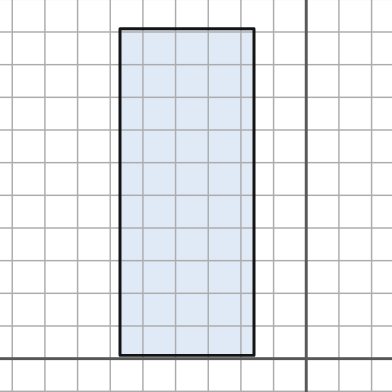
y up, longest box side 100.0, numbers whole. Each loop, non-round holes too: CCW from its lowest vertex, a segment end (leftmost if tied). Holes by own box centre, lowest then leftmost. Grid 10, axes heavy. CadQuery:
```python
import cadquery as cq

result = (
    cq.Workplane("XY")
    .moveTo(-57.0, 1.0)
    .lineTo(-16.0, 1.0)
    .lineTo(-16.0, 101.0)
    .lineTo(-57.0, 101.0)
    .close()
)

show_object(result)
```